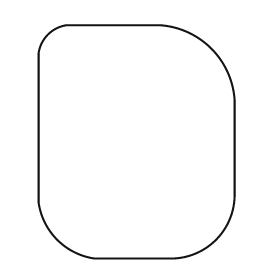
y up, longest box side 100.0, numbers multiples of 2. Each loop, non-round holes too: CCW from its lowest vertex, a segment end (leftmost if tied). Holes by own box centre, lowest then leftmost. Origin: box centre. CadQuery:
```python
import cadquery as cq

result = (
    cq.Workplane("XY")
    .moveTo(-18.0, -50.0)
    .lineTo(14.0, -50.0)
    .threePointArc((34.0, -42.0), (42.0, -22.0))
    .lineTo(42.0, 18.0)
    .threePointArc((32.0, 40.0), (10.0, 50.0))
    .lineTo(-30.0, 50.0)
    .threePointArc((-38.0, 46.0), (-42.0, 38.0))
    .lineTo(-42.0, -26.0)
    .threePointArc((-34.0, -42.0), (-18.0, -50.0))
    .close()
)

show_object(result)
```